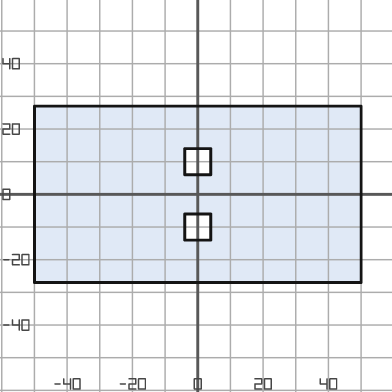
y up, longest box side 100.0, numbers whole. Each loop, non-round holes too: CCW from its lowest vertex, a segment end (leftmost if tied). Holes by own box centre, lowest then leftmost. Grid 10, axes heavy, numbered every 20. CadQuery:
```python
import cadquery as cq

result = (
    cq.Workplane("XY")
    .moveTo(-50.0, -27.0)
    .lineTo(50.0, -27.0)
    .lineTo(50.0, 27.0)
    .lineTo(-50.0, 27.0)
    .close()
    .moveTo(-4.0, -14.0)
    .lineTo(4.0, -14.0)
    .lineTo(4.0, -6.0)
    .lineTo(-4.0, -6.0)
    .close()
    .moveTo(-4.0, 6.0)
    .lineTo(4.0, 6.0)
    .lineTo(4.0, 14.0)
    .lineTo(-4.0, 14.0)
    .close()
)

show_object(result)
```